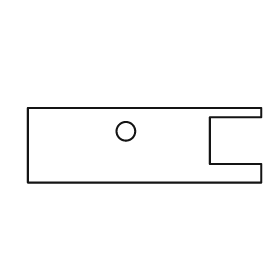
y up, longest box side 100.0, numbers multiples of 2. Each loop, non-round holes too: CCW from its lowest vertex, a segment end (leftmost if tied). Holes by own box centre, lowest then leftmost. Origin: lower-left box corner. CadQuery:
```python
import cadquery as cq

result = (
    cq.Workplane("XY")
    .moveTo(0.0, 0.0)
    .lineTo(100.0, 0.0)
    .lineTo(100.0, 8.0)
    .lineTo(78.0, 8.0)
    .lineTo(78.0, 28.0)
    .lineTo(100.0, 28.0)
    .lineTo(100.0, 32.0)
    .lineTo(0.0, 32.0)
    .close()
    .moveTo(42.0, 22.0)
    .circle(4.0)
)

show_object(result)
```